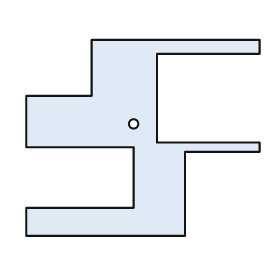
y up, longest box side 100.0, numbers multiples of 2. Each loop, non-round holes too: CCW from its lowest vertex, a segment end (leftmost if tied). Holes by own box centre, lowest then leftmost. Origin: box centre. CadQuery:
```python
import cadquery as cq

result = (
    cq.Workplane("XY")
    .moveTo(-50.0, -42.0)
    .lineTo(18.0, -42.0)
    .lineTo(18.0, -6.0)
    .lineTo(50.0, -6.0)
    .lineTo(50.0, -2.0)
    .lineTo(6.0, -2.0)
    .lineTo(6.0, 36.0)
    .lineTo(50.0, 36.0)
    .lineTo(50.0, 42.0)
    .lineTo(-22.0, 42.0)
    .lineTo(-22.0, 18.0)
    .lineTo(-50.0, 18.0)
    .lineTo(-50.0, -4.0)
    .lineTo(-4.0, -4.0)
    .lineTo(-4.0, -30.0)
    .lineTo(-50.0, -30.0)
    .close()
    .moveTo(-4.0, 6.0)
    .circle(2.0)
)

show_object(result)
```